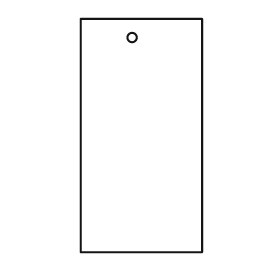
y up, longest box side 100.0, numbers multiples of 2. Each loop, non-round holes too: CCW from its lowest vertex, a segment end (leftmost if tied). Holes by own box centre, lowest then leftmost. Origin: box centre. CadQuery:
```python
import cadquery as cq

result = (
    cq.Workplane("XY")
    .moveTo(-26.0, -50.0)
    .lineTo(26.0, -50.0)
    .lineTo(26.0, 50.0)
    .lineTo(-26.0, 50.0)
    .close()
    .moveTo(-4.0, 42.0)
    .circle(2.0)
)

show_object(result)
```